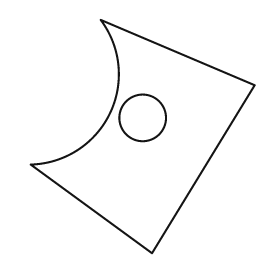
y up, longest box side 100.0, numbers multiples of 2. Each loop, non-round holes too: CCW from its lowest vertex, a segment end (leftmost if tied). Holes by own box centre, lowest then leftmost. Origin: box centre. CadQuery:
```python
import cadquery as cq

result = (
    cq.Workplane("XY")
    .moveTo(4.0, -50.0)
    .lineTo(48.0, 22.0)
    .lineTo(-18.0, 50.0)
    .threePointArc((-14.0, 10.0), (-48.0, -12.0))
    .close()
    .moveTo(0.0, 8.0)
    .circle(10.0)
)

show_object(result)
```